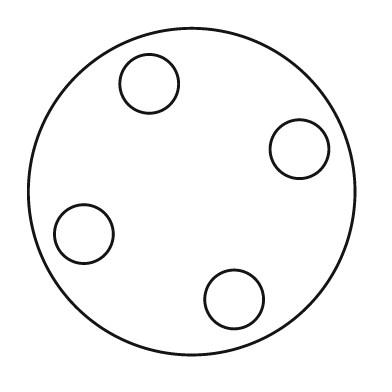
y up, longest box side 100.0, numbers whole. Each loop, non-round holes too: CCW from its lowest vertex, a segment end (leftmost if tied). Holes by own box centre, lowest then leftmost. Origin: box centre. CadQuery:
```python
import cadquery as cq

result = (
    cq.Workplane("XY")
    .moveTo(0.0, 0.0)
    .circle(50.0)
    .moveTo(13.0, -33.0)
    .circle(9.0)
    .moveTo(-33.0, -13.0)
    .circle(9.0)
    .moveTo(33.0, 13.0)
    .circle(9.0)
    .moveTo(-13.0, 33.0)
    .circle(9.0)
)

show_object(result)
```